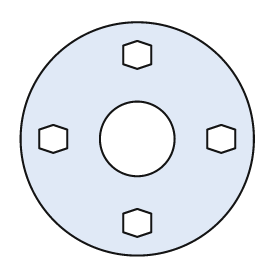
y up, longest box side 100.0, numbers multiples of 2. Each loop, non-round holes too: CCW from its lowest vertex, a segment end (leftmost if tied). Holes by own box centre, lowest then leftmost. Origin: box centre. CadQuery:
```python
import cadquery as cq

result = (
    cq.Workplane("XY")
    .moveTo(0.0, 0.0)
    .circle(50.0)
    .moveTo(0.0, -42.0)
    .lineTo(6.0, -40.0)
    .lineTo(6.0, -32.0)
    .lineTo(0.0, -30.0)
    .lineTo(-6.0, -32.0)
    .lineTo(-6.0, -40.0)
    .close()
    .moveTo(-36.0, -6.0)
    .lineTo(-30.0, -4.0)
    .lineTo(-30.0, 4.0)
    .lineTo(-36.0, 6.0)
    .lineTo(-42.0, 4.0)
    .lineTo(-42.0, -4.0)
    .close()
    .moveTo(0.0, 0.0)
    .circle(16.0)
    .moveTo(36.0, -6.0)
    .lineTo(42.0, -4.0)
    .lineTo(42.0, 4.0)
    .lineTo(36.0, 6.0)
    .lineTo(30.0, 4.0)
    .lineTo(30.0, -4.0)
    .close()
    .moveTo(0.0, 30.0)
    .lineTo(6.0, 32.0)
    .lineTo(6.0, 40.0)
    .lineTo(0.0, 42.0)
    .lineTo(-6.0, 40.0)
    .lineTo(-6.0, 32.0)
    .close()
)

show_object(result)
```